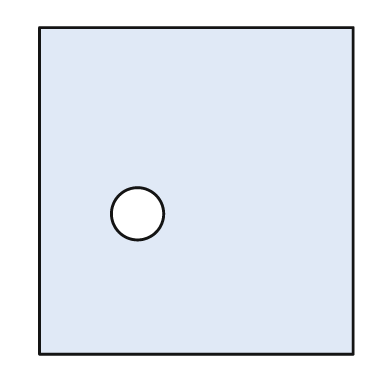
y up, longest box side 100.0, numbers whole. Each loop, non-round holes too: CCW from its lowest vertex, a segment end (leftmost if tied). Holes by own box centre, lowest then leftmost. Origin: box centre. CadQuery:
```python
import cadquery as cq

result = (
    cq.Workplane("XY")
    .moveTo(-48.0, -50.0)
    .lineTo(48.0, -50.0)
    .lineTo(48.0, 50.0)
    .lineTo(-48.0, 50.0)
    .close()
    .moveTo(-18.0, -7.0)
    .circle(8.0)
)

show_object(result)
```